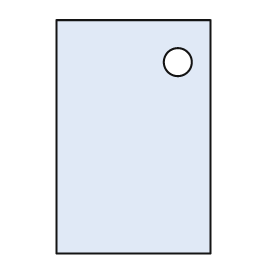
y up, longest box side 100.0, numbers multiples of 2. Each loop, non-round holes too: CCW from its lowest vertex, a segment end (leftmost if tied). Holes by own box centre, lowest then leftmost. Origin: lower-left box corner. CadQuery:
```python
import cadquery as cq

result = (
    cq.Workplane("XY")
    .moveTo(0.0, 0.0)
    .lineTo(66.0, 0.0)
    .lineTo(66.0, 100.0)
    .lineTo(0.0, 100.0)
    .close()
    .moveTo(52.0, 82.0)
    .circle(6.0)
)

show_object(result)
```